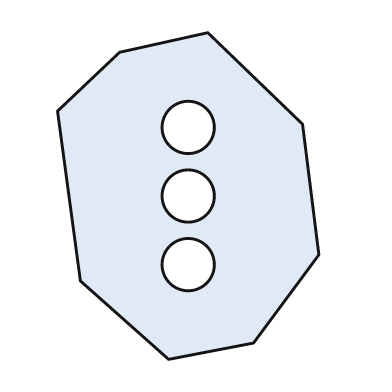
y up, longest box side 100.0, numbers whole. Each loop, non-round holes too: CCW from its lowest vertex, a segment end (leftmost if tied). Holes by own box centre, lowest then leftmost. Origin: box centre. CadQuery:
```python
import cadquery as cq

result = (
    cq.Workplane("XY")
    .moveTo(-6.0, -50.0)
    .lineTo(20.0, -45.0)
    .lineTo(40.0, -18.0)
    .lineTo(35.0, 22.0)
    .lineTo(6.0, 50.0)
    .lineTo(-21.0, 44.0)
    .lineTo(-40.0, 26.0)
    .lineTo(-33.0, -26.0)
    .close()
    .moveTo(0.0, -21.0)
    .circle(8.0)
    .moveTo(0.0, 0.0)
    .circle(8.0)
    .moveTo(0.0, 21.0)
    .circle(8.0)
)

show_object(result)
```